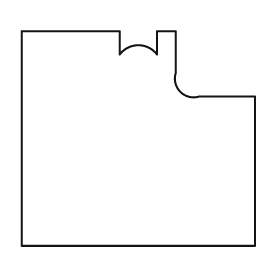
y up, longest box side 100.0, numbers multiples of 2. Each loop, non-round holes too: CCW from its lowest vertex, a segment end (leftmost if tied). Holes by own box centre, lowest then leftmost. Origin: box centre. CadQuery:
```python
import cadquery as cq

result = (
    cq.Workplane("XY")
    .moveTo(-50.0, -46.0)
    .lineTo(50.0, -46.0)
    .lineTo(50.0, 18.0)
    .lineTo(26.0, 18.0)
    .threePointArc((18.0, 20.0), (16.0, 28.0))
    .lineTo(16.0, 46.0)
    .lineTo(8.0, 46.0)
    .lineTo(8.0, 36.0)
    .threePointArc((0.0, 40.0), (-8.0, 36.0))
    .lineTo(-8.0, 46.0)
    .lineTo(-50.0, 46.0)
    .close()
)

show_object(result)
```